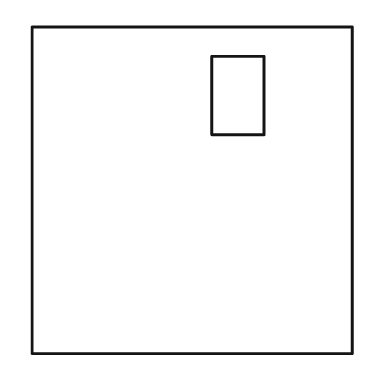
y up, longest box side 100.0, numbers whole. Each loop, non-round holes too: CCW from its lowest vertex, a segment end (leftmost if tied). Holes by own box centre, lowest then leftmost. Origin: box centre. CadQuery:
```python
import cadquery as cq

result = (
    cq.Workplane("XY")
    .moveTo(-49.0, -50.0)
    .lineTo(49.0, -50.0)
    .lineTo(49.0, 50.0)
    .lineTo(-49.0, 50.0)
    .close()
    .moveTo(6.0, 17.0)
    .lineTo(22.0, 17.0)
    .lineTo(22.0, 41.0)
    .lineTo(6.0, 41.0)
    .close()
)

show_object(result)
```